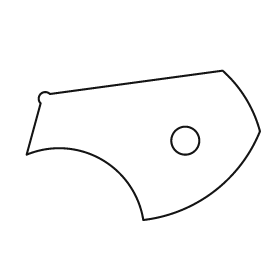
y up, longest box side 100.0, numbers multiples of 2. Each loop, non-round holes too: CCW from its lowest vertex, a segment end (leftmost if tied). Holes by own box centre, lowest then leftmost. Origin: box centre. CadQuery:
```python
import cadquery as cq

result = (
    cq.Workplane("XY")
    .moveTo(0.0, -32.0)
    .threePointArc((30.0, -20.0), (50.0, 6.0))
    .threePointArc((44.0, 20.0), (34.0, 32.0))
    .lineTo(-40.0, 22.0)
    .threePointArc((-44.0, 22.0), (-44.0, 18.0))
    .lineTo(-50.0, -4.0)
    .threePointArc((-18.0, -6.0), (0.0, -32.0))
    .close()
    .moveTo(18.0, 2.0)
    .circle(6.0)
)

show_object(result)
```